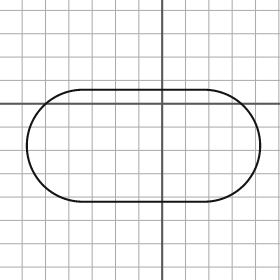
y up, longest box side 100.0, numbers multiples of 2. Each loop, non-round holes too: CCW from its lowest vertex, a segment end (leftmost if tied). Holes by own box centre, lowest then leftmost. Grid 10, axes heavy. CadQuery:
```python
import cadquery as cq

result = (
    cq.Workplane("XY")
    .moveTo(-34.0, -42.0)
    .lineTo(18.0, -42.0)
    .threePointArc((42.0, -18.0), (18.0, 6.0))
    .lineTo(-34.0, 6.0)
    .threePointArc((-58.0, -18.0), (-34.0, -42.0))
    .close()
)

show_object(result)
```